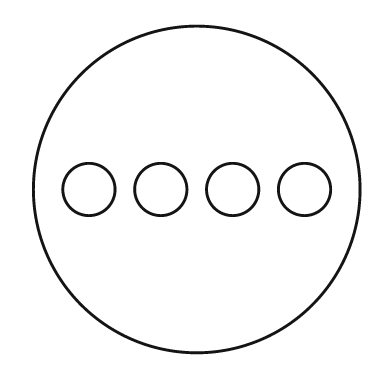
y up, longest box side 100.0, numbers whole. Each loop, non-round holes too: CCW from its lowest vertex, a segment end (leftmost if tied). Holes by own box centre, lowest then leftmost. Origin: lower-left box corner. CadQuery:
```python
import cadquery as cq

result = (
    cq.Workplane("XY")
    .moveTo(50.0, 50.0)
    .circle(50.0)
    .moveTo(17.0, 50.0)
    .circle(8.0)
    .moveTo(39.0, 50.0)
    .circle(8.0)
    .moveTo(61.0, 50.0)
    .circle(8.0)
    .moveTo(83.0, 50.0)
    .circle(8.0)
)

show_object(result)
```